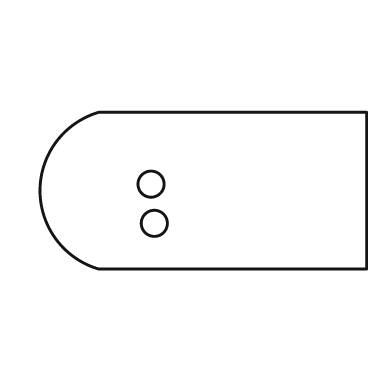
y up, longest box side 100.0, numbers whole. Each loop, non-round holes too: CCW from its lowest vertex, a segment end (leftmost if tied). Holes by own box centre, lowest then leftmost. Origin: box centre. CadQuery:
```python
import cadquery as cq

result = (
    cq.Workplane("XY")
    .moveTo(-32.0, -24.0)
    .lineTo(50.0, -24.0)
    .lineTo(50.0, 24.0)
    .lineTo(-32.0, 24.0)
    .threePointArc((-50.0, 0.0), (-32.0, -24.0))
    .close()
    .moveTo(-15.0, -10.0)
    .circle(4.0)
    .moveTo(-16.0, 2.0)
    .circle(4.0)
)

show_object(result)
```